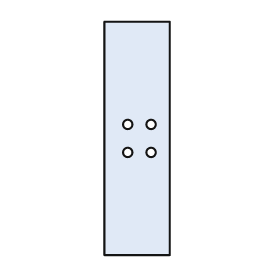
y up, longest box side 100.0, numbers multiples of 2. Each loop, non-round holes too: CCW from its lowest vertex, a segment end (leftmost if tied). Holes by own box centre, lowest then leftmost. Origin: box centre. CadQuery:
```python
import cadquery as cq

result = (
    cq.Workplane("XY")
    .moveTo(-14.0, -50.0)
    .lineTo(14.0, -50.0)
    .lineTo(14.0, 50.0)
    .lineTo(-14.0, 50.0)
    .close()
    .moveTo(-4.0, -6.0)
    .circle(2.0)
    .moveTo(6.0, -6.0)
    .circle(2.0)
    .moveTo(-4.0, 6.0)
    .circle(2.0)
    .moveTo(6.0, 6.0)
    .circle(2.0)
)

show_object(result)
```